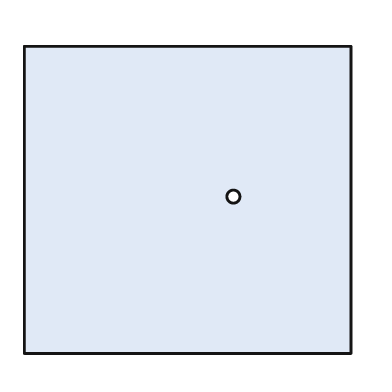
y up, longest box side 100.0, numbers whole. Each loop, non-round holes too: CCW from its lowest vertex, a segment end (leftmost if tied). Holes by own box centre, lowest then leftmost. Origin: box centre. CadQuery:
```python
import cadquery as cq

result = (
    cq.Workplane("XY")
    .moveTo(-50.0, -47.0)
    .lineTo(50.0, -47.0)
    .lineTo(50.0, 47.0)
    .lineTo(-50.0, 47.0)
    .close()
    .moveTo(14.0, 1.0)
    .circle(2.0)
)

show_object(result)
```